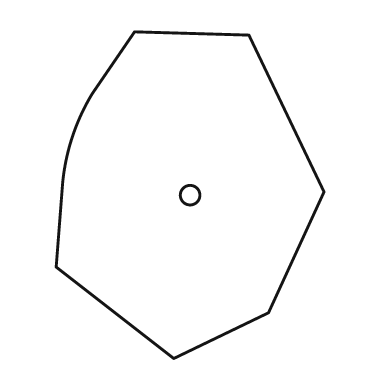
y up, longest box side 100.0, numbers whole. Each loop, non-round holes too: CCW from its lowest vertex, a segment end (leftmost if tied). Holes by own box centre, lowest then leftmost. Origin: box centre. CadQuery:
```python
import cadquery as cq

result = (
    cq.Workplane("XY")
    .moveTo(-5.0, -50.0)
    .lineTo(24.0, -36.0)
    .lineTo(41.0, 1.0)
    .lineTo(18.0, 49.0)
    .lineTo(-17.0, 50.0)
    .lineTo(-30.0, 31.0)
    .threePointArc((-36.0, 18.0), (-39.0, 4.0))
    .lineTo(-41.0, -22.0)
    .close()
    .moveTo(0.0, 0.0)
    .circle(3.0)
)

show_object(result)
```